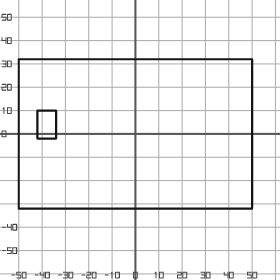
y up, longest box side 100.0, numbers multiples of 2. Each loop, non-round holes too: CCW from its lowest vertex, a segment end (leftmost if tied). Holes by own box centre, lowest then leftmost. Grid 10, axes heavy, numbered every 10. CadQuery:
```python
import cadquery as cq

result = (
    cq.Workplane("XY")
    .moveTo(-50.0, -32.0)
    .lineTo(50.0, -32.0)
    .lineTo(50.0, 32.0)
    .lineTo(-50.0, 32.0)
    .close()
    .moveTo(-42.0, -2.0)
    .lineTo(-34.0, -2.0)
    .lineTo(-34.0, 10.0)
    .lineTo(-42.0, 10.0)
    .close()
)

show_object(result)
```